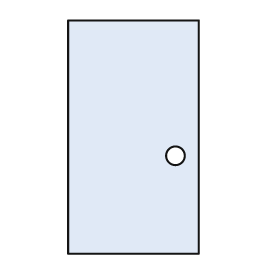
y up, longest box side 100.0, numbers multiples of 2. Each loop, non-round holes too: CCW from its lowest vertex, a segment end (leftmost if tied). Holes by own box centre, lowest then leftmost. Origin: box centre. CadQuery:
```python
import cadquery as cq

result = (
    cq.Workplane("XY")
    .moveTo(-28.0, -50.0)
    .lineTo(28.0, -50.0)
    .lineTo(28.0, 50.0)
    .lineTo(-28.0, 50.0)
    .close()
    .moveTo(18.0, -8.0)
    .circle(4.0)
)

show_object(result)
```